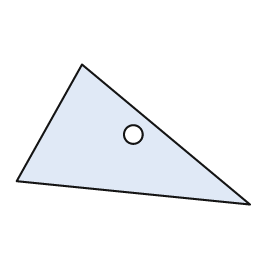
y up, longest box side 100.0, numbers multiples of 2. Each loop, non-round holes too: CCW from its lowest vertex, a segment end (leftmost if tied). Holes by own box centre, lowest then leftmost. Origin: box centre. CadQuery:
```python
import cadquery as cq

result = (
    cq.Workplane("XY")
    .moveTo(50.0, -30.0)
    .lineTo(-22.0, 30.0)
    .lineTo(-50.0, -20.0)
    .close()
    .moveTo(0.0, 0.0)
    .circle(4.0)
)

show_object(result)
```